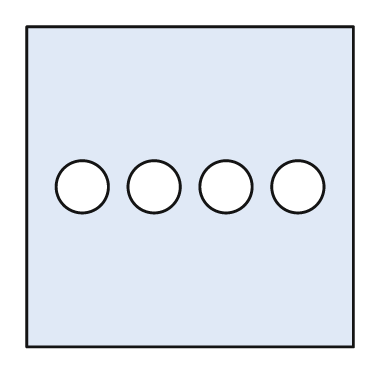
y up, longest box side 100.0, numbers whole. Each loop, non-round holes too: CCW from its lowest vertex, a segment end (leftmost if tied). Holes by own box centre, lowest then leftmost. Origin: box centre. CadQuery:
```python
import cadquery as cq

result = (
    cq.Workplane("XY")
    .moveTo(-50.0, -49.0)
    .lineTo(50.0, -49.0)
    .lineTo(50.0, 49.0)
    .lineTo(-50.0, 49.0)
    .close()
    .moveTo(-33.0, 0.0)
    .circle(8.0)
    .moveTo(-11.0, 0.0)
    .circle(8.0)
    .moveTo(11.0, 0.0)
    .circle(8.0)
    .moveTo(33.0, 0.0)
    .circle(8.0)
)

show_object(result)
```